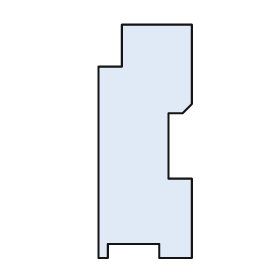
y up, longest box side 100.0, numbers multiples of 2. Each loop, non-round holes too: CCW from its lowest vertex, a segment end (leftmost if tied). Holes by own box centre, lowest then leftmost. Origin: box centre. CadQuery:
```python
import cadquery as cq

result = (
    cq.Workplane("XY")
    .moveTo(-20.0, -50.0)
    .lineTo(-16.0, -50.0)
    .lineTo(-16.0, -44.0)
    .lineTo(6.0, -44.0)
    .lineTo(6.0, -50.0)
    .lineTo(20.0, -50.0)
    .lineTo(20.0, -16.0)
    .lineTo(10.0, -16.0)
    .lineTo(10.0, 12.0)
    .lineTo(16.0, 12.0)
    .lineTo(20.0, 16.0)
    .lineTo(20.0, 50.0)
    .lineTo(-10.0, 50.0)
    .lineTo(-10.0, 32.0)
    .lineTo(-20.0, 32.0)
    .close()
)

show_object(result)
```